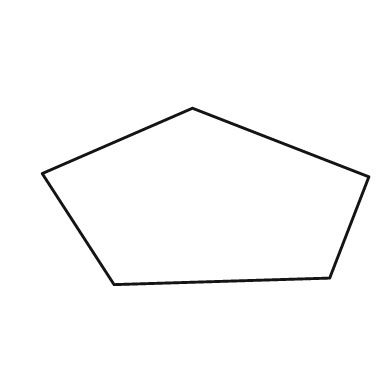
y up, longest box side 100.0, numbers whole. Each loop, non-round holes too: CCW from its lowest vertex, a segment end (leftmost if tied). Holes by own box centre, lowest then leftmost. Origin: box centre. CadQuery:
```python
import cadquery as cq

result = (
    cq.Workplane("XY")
    .moveTo(-28.0, -27.0)
    .lineTo(38.0, -25.0)
    .lineTo(50.0, 6.0)
    .lineTo(-4.0, 27.0)
    .lineTo(-50.0, 7.0)
    .close()
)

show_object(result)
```